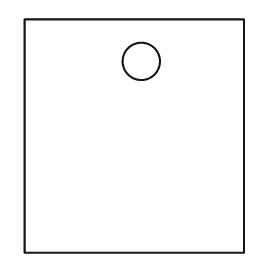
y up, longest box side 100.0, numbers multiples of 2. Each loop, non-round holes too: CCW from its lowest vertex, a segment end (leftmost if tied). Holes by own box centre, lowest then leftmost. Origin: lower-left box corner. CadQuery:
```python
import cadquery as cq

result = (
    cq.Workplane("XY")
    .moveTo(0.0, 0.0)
    .lineTo(94.0, 0.0)
    .lineTo(94.0, 100.0)
    .lineTo(0.0, 100.0)
    .close()
    .moveTo(50.0, 82.0)
    .circle(8.0)
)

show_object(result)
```